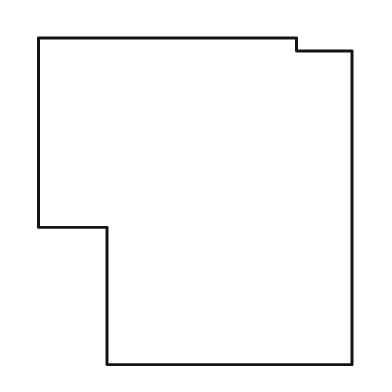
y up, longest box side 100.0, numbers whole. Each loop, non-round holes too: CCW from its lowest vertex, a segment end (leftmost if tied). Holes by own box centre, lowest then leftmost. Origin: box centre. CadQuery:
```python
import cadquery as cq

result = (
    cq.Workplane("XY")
    .moveTo(-27.0, -50.0)
    .lineTo(48.0, -50.0)
    .lineTo(48.0, 46.0)
    .lineTo(31.0, 46.0)
    .lineTo(31.0, 50.0)
    .lineTo(-48.0, 50.0)
    .lineTo(-48.0, -8.0)
    .lineTo(-27.0, -8.0)
    .close()
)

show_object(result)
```